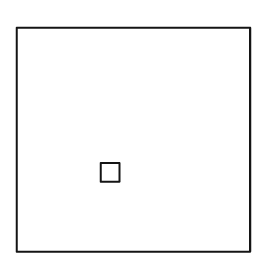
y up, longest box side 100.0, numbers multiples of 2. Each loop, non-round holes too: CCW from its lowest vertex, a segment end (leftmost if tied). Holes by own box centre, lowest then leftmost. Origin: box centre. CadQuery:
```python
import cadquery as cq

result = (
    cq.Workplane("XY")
    .moveTo(-50.0, -48.0)
    .lineTo(50.0, -48.0)
    .lineTo(50.0, 48.0)
    .lineTo(-50.0, 48.0)
    .close()
    .moveTo(-14.0, -18.0)
    .lineTo(-6.0, -18.0)
    .lineTo(-6.0, -10.0)
    .lineTo(-14.0, -10.0)
    .close()
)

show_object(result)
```